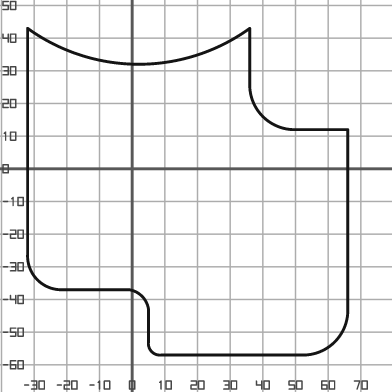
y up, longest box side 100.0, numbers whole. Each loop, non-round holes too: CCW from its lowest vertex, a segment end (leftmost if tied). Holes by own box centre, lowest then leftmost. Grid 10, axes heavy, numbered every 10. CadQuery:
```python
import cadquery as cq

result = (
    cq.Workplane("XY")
    .moveTo(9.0, -57.0)
    .lineTo(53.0, -57.0)
    .threePointArc((62.0, -53.0), (66.0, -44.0))
    .lineTo(66.0, 12.0)
    .lineTo(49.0, 12.0)
    .threePointArc((40.0, 16.0), (36.0, 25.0))
    .lineTo(36.0, 43.0)
    .threePointArc((2.0, 32.0), (-32.0, 43.0))
    .lineTo(-32.0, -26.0)
    .threePointArc((-29.0, -34.0), (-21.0, -37.0))
    .lineTo(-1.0, -37.0)
    .threePointArc((3.0, -39.0), (5.0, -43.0))
    .lineTo(5.0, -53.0)
    .threePointArc((6.0, -56.0), (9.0, -57.0))
    .close()
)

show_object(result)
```